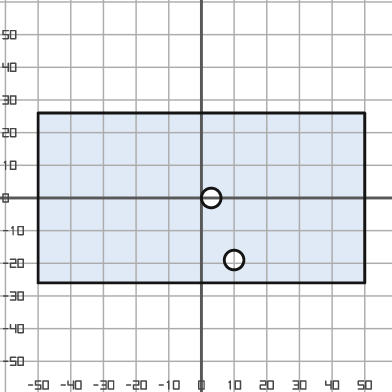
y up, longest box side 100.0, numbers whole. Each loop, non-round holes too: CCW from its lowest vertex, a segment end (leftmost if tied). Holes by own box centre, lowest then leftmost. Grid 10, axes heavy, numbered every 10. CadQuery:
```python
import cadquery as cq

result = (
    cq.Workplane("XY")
    .moveTo(-50.0, -26.0)
    .lineTo(50.0, -26.0)
    .lineTo(50.0, 26.0)
    .lineTo(-50.0, 26.0)
    .close()
    .moveTo(10.0, -19.0)
    .circle(3.0)
    .moveTo(3.0, 0.0)
    .circle(3.0)
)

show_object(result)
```